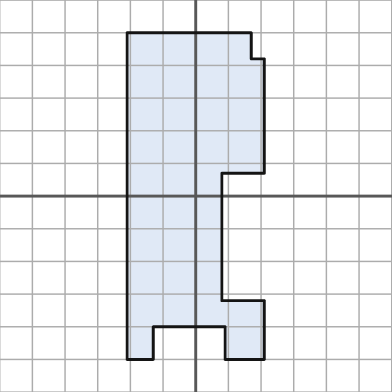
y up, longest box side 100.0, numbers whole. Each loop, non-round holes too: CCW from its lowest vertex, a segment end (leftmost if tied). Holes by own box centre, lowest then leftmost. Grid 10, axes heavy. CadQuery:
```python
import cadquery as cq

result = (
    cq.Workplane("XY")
    .moveTo(-21.0, -50.0)
    .lineTo(-13.0, -50.0)
    .lineTo(-13.0, -40.0)
    .lineTo(9.0, -40.0)
    .lineTo(9.0, -50.0)
    .lineTo(21.0, -50.0)
    .lineTo(21.0, -32.0)
    .lineTo(8.0, -32.0)
    .lineTo(8.0, 7.0)
    .lineTo(21.0, 7.0)
    .lineTo(21.0, 42.0)
    .lineTo(17.0, 42.0)
    .lineTo(17.0, 50.0)
    .lineTo(-21.0, 50.0)
    .close()
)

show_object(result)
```